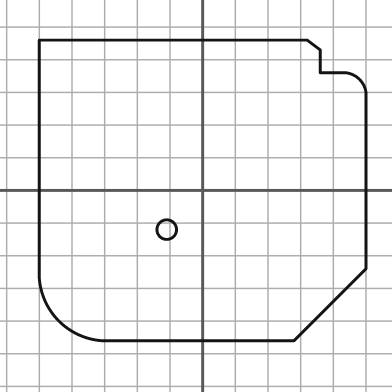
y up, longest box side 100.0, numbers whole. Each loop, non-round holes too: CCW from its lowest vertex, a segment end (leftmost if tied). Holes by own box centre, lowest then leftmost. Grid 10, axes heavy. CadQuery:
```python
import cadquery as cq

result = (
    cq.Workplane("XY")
    .moveTo(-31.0, -46.0)
    .lineTo(28.0, -46.0)
    .lineTo(50.0, -24.0)
    .lineTo(50.0, 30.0)
    .threePointArc((48.0, 34.0), (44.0, 36.0))
    .lineTo(36.0, 36.0)
    .lineTo(36.0, 43.0)
    .lineTo(32.0, 46.0)
    .lineTo(-50.0, 46.0)
    .lineTo(-50.0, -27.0)
    .threePointArc((-44.0, -40.0), (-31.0, -46.0))
    .close()
    .moveTo(-11.0, -12.0)
    .circle(3.0)
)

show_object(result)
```